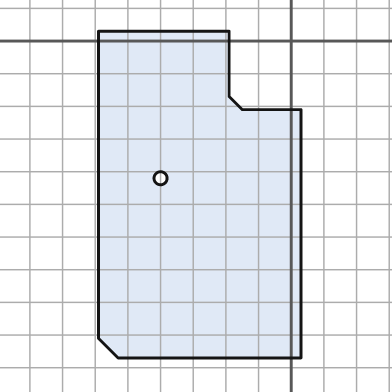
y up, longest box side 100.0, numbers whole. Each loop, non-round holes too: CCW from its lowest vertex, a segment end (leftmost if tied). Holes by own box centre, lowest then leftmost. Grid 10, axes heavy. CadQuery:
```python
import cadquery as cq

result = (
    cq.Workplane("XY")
    .moveTo(-53.0, -97.0)
    .lineTo(3.0, -97.0)
    .lineTo(3.0, -21.0)
    .lineTo(-15.0, -21.0)
    .lineTo(-19.0, -17.0)
    .lineTo(-19.0, 3.0)
    .lineTo(-59.0, 3.0)
    .lineTo(-59.0, -91.0)
    .close()
    .moveTo(-40.0, -42.0)
    .circle(2.0)
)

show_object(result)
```